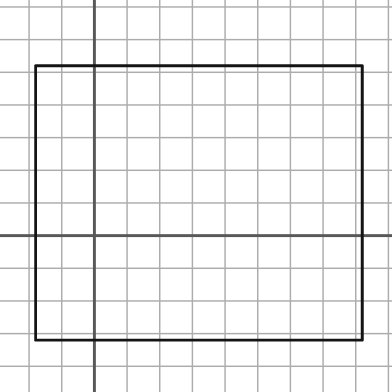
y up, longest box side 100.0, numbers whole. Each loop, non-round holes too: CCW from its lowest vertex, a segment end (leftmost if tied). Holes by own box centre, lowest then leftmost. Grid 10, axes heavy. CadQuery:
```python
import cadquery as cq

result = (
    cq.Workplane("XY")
    .moveTo(-18.0, -32.0)
    .lineTo(82.0, -32.0)
    .lineTo(82.0, 52.0)
    .lineTo(-18.0, 52.0)
    .close()
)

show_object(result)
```